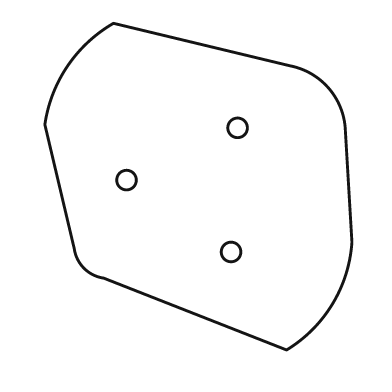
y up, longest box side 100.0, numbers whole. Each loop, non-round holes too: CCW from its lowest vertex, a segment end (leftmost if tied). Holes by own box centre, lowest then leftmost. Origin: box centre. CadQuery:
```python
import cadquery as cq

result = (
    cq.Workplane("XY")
    .moveTo(27.0, -50.0)
    .threePointArc((41.0, -36.0), (47.0, -17.0))
    .lineTo(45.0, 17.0)
    .threePointArc((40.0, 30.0), (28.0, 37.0))
    .lineTo(-26.0, 50.0)
    .threePointArc((-40.0, 37.0), (-47.0, 19.0))
    .lineTo(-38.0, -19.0)
    .threePointArc((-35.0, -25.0), (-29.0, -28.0))
    .close()
    .moveTo(10.0, -20.0)
    .circle(3.0)
    .moveTo(-22.0, 2.0)
    .circle(3.0)
    .moveTo(12.0, 18.0)
    .circle(3.0)
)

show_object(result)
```